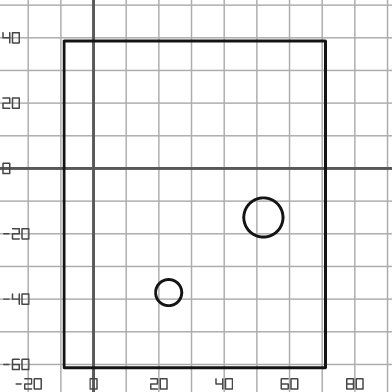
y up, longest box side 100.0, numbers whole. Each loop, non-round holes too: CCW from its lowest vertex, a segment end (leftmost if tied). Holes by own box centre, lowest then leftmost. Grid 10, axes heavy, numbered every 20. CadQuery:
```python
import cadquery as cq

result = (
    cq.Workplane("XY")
    .moveTo(-9.0, -61.0)
    .lineTo(71.0, -61.0)
    .lineTo(71.0, 39.0)
    .lineTo(-9.0, 39.0)
    .close()
    .moveTo(23.0, -38.0)
    .circle(4.0)
    .moveTo(52.0, -15.0)
    .circle(6.0)
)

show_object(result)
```